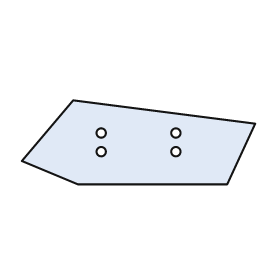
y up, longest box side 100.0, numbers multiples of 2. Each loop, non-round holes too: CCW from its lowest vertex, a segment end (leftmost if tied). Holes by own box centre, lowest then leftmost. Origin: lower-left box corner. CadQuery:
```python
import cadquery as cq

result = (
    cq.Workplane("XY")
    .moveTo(24.0, 0.0)
    .lineTo(88.0, 0.0)
    .lineTo(100.0, 26.0)
    .lineTo(22.0, 36.0)
    .lineTo(0.0, 10.0)
    .close()
    .moveTo(34.0, 14.0)
    .circle(2.0)
    .moveTo(66.0, 14.0)
    .circle(2.0)
    .moveTo(34.0, 22.0)
    .circle(2.0)
    .moveTo(66.0, 22.0)
    .circle(2.0)
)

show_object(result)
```